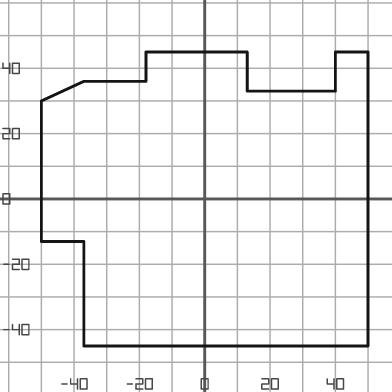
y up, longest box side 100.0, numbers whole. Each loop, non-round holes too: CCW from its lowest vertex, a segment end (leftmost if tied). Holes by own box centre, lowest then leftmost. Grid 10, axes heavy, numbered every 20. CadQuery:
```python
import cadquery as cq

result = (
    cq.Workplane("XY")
    .moveTo(-37.0, -45.0)
    .lineTo(50.0, -45.0)
    .lineTo(50.0, 45.0)
    .lineTo(40.0, 45.0)
    .lineTo(40.0, 33.0)
    .lineTo(13.0, 33.0)
    .lineTo(13.0, 45.0)
    .lineTo(-18.0, 45.0)
    .lineTo(-18.0, 36.0)
    .lineTo(-37.0, 36.0)
    .lineTo(-50.0, 30.0)
    .lineTo(-50.0, -13.0)
    .lineTo(-37.0, -13.0)
    .close()
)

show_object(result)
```